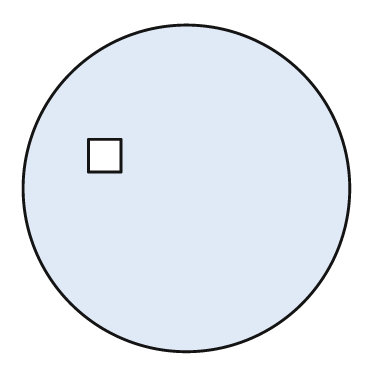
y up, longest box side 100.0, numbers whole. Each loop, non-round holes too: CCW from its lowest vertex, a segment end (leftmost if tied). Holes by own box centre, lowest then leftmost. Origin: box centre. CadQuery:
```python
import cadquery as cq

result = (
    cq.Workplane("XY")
    .moveTo(0.0, 0.0)
    .circle(50.0)
    .moveTo(-30.0, 5.0)
    .lineTo(-20.0, 5.0)
    .lineTo(-20.0, 15.0)
    .lineTo(-30.0, 15.0)
    .close()
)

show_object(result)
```